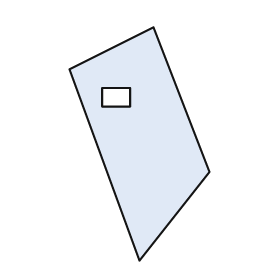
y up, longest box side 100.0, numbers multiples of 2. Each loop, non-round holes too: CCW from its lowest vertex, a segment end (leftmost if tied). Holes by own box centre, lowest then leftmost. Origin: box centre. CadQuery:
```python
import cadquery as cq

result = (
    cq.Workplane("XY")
    .moveTo(0.0, -50.0)
    .lineTo(30.0, -12.0)
    .lineTo(6.0, 50.0)
    .lineTo(-30.0, 32.0)
    .close()
    .moveTo(-16.0, 16.0)
    .lineTo(-4.0, 16.0)
    .lineTo(-4.0, 24.0)
    .lineTo(-16.0, 24.0)
    .close()
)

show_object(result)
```